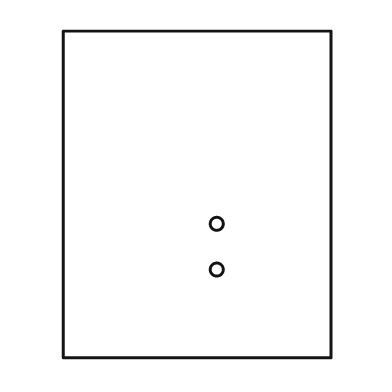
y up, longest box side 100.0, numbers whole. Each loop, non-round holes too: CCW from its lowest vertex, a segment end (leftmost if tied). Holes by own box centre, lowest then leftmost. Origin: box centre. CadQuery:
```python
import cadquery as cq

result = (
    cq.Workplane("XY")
    .moveTo(-41.0, -50.0)
    .lineTo(41.0, -50.0)
    .lineTo(41.0, 50.0)
    .lineTo(-41.0, 50.0)
    .close()
    .moveTo(6.0, -23.0)
    .circle(2.0)
    .moveTo(6.0, -9.0)
    .circle(2.0)
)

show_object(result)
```